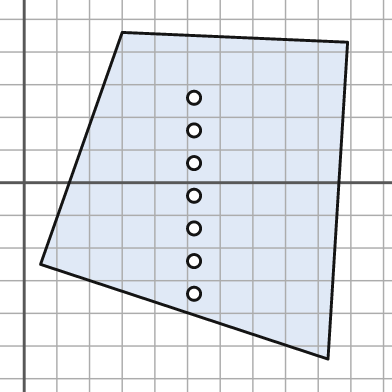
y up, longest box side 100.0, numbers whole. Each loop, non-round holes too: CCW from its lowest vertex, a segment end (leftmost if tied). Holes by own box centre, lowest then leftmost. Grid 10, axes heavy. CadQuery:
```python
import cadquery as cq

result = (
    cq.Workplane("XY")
    .moveTo(93.0, -54.0)
    .lineTo(99.0, 43.0)
    .lineTo(30.0, 46.0)
    .lineTo(5.0, -25.0)
    .close()
    .moveTo(52.0, -34.0)
    .circle(2.0)
    .moveTo(52.0, -24.0)
    .circle(2.0)
    .moveTo(52.0, -14.0)
    .circle(2.0)
    .moveTo(52.0, -4.0)
    .circle(2.0)
    .moveTo(52.0, 6.0)
    .circle(2.0)
    .moveTo(52.0, 16.0)
    .circle(2.0)
    .moveTo(52.0, 26.0)
    .circle(2.0)
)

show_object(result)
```